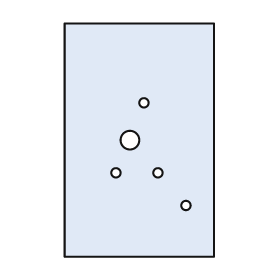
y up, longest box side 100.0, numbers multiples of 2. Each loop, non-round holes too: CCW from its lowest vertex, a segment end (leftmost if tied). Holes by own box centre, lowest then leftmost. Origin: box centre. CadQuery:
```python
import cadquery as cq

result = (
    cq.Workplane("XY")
    .moveTo(-32.0, -50.0)
    .lineTo(32.0, -50.0)
    .lineTo(32.0, 50.0)
    .lineTo(-32.0, 50.0)
    .close()
    .moveTo(20.0, -28.0)
    .circle(2.0)
    .moveTo(-10.0, -14.0)
    .circle(2.0)
    .moveTo(8.0, -14.0)
    .circle(2.0)
    .moveTo(-4.0, 0.0)
    .circle(4.0)
    .moveTo(2.0, 16.0)
    .circle(2.0)
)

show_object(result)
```